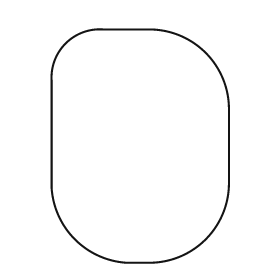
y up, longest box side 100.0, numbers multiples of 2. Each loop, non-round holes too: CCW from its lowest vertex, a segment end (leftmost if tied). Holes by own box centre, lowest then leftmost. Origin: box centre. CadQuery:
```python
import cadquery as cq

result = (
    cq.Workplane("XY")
    .moveTo(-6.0, -50.0)
    .lineTo(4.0, -50.0)
    .threePointArc((28.0, -40.0), (38.0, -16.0))
    .lineTo(38.0, 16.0)
    .threePointArc((28.0, 40.0), (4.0, 50.0))
    .lineTo(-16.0, 50.0)
    .threePointArc((-32.0, 44.0), (-38.0, 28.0))
    .lineTo(-38.0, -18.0)
    .threePointArc((-28.0, -40.0), (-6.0, -50.0))
    .close()
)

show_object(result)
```